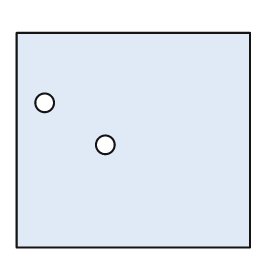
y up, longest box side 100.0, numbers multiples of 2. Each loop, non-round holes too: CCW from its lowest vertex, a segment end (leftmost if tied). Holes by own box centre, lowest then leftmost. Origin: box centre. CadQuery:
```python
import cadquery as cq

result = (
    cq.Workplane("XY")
    .moveTo(-50.0, -46.0)
    .lineTo(50.0, -46.0)
    .lineTo(50.0, 46.0)
    .lineTo(-50.0, 46.0)
    .close()
    .moveTo(-12.0, -2.0)
    .circle(4.0)
    .moveTo(-38.0, 16.0)
    .circle(4.0)
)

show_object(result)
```